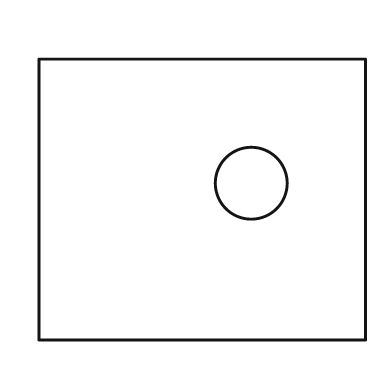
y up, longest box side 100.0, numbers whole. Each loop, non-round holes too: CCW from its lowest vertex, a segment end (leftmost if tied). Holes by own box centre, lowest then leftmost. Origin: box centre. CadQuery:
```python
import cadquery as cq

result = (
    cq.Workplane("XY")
    .moveTo(-50.0, -43.0)
    .lineTo(50.0, -43.0)
    .lineTo(50.0, 43.0)
    .lineTo(-50.0, 43.0)
    .close()
    .moveTo(15.0, 5.0)
    .circle(11.0)
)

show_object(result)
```